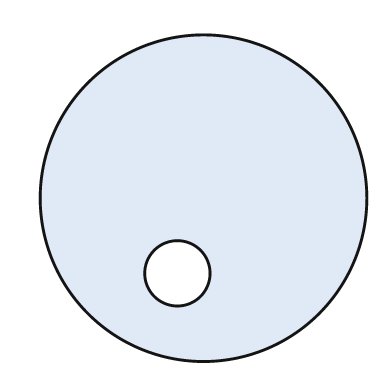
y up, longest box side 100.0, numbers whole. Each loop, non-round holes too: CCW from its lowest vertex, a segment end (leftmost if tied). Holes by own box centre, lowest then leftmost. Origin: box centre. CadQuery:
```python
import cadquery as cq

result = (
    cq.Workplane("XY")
    .moveTo(0.0, 0.0)
    .circle(50.0)
    .moveTo(-8.0, -23.0)
    .circle(10.0)
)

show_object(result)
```